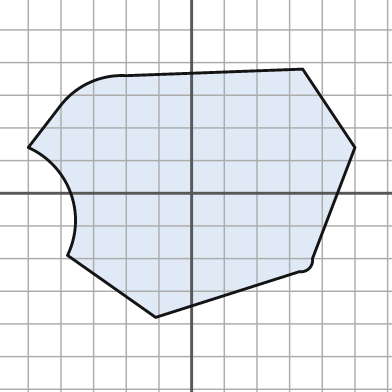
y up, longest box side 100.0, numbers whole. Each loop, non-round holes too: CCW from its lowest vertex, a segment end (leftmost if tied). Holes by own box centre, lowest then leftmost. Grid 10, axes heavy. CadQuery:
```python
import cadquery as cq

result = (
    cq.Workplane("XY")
    .moveTo(-11.0, -38.0)
    .lineTo(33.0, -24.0)
    .threePointArc((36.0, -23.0), (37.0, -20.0))
    .lineTo(50.0, 14.0)
    .lineTo(34.0, 38.0)
    .lineTo(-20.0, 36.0)
    .threePointArc((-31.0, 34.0), (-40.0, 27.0))
    .lineTo(-50.0, 14.0)
    .threePointArc((-37.0, 0.0), (-38.0, -19.0))
    .close()
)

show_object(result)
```